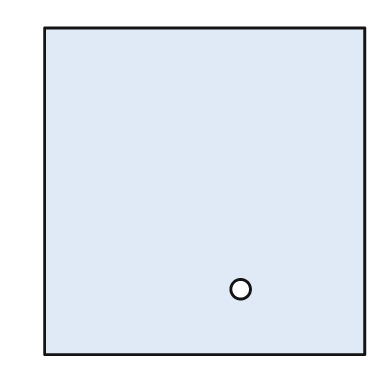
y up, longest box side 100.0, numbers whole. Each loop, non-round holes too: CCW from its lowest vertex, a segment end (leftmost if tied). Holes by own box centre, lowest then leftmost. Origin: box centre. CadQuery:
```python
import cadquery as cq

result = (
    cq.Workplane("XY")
    .moveTo(-49.0, -50.0)
    .lineTo(49.0, -50.0)
    .lineTo(49.0, 50.0)
    .lineTo(-49.0, 50.0)
    .close()
    .moveTo(11.0, -30.0)
    .circle(3.0)
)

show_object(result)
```